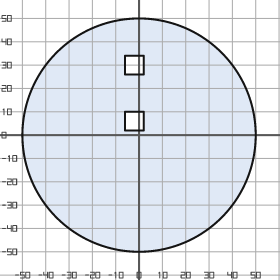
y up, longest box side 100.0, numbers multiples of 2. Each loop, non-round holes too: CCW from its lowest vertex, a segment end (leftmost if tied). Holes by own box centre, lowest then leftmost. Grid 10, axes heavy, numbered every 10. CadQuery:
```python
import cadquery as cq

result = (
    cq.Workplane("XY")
    .moveTo(0.0, 0.0)
    .circle(50.0)
    .moveTo(-6.0, 2.0)
    .lineTo(2.0, 2.0)
    .lineTo(2.0, 10.0)
    .lineTo(-6.0, 10.0)
    .close()
    .moveTo(-6.0, 26.0)
    .lineTo(2.0, 26.0)
    .lineTo(2.0, 34.0)
    .lineTo(-6.0, 34.0)
    .close()
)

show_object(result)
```